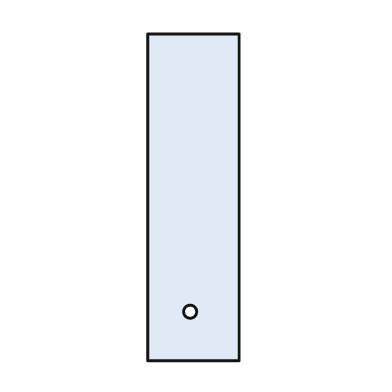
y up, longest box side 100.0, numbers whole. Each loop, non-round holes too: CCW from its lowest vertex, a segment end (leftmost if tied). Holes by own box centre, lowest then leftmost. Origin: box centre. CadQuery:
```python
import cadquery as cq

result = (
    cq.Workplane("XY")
    .moveTo(-14.0, -50.0)
    .lineTo(14.0, -50.0)
    .lineTo(14.0, 50.0)
    .lineTo(-14.0, 50.0)
    .close()
    .moveTo(-1.0, -35.0)
    .circle(2.0)
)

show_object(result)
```